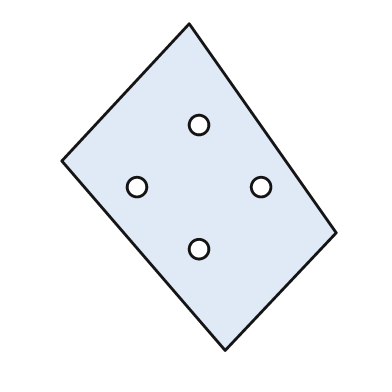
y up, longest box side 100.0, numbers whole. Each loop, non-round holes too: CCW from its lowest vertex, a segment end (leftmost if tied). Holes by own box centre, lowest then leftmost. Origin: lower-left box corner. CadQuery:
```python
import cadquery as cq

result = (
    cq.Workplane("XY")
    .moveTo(50.0, 0.0)
    .lineTo(84.0, 36.0)
    .lineTo(39.0, 100.0)
    .lineTo(0.0, 58.0)
    .close()
    .moveTo(42.0, 31.0)
    .circle(3.0)
    .moveTo(23.0, 50.0)
    .circle(3.0)
    .moveTo(61.0, 50.0)
    .circle(3.0)
    .moveTo(42.0, 69.0)
    .circle(3.0)
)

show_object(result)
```